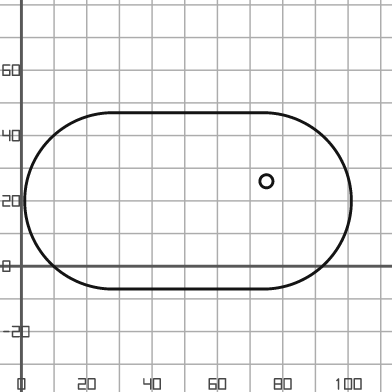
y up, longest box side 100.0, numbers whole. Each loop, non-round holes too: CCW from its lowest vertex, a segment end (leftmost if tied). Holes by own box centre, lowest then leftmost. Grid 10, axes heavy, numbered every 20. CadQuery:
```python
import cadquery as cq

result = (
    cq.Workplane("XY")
    .moveTo(28.0, -7.0)
    .lineTo(74.0, -7.0)
    .threePointArc((101.0, 20.0), (74.0, 47.0))
    .lineTo(28.0, 47.0)
    .threePointArc((1.0, 20.0), (28.0, -7.0))
    .close()
    .moveTo(75.0, 26.0)
    .circle(2.0)
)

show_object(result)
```